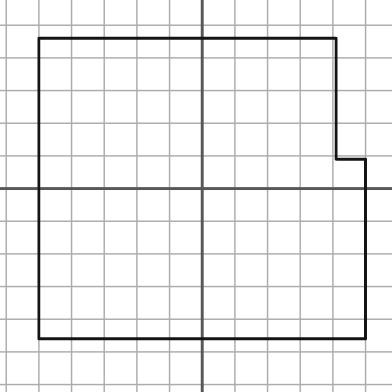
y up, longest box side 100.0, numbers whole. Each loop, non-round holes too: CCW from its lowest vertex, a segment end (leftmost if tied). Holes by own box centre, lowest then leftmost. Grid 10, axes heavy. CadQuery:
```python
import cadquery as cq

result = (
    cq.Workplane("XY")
    .moveTo(-50.0, -46.0)
    .lineTo(50.0, -46.0)
    .lineTo(50.0, 9.0)
    .lineTo(41.0, 9.0)
    .lineTo(41.0, 46.0)
    .lineTo(-50.0, 46.0)
    .close()
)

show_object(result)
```